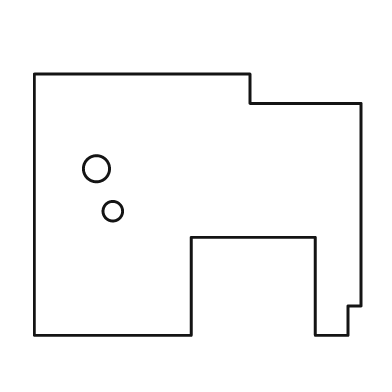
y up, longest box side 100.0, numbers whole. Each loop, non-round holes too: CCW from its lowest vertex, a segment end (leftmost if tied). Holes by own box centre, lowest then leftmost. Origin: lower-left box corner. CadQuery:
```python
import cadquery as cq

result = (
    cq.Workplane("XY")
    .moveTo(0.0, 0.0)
    .lineTo(48.0, 0.0)
    .lineTo(48.0, 30.0)
    .lineTo(86.0, 30.0)
    .lineTo(86.0, 0.0)
    .lineTo(96.0, 0.0)
    .lineTo(96.0, 9.0)
    .lineTo(100.0, 9.0)
    .lineTo(100.0, 71.0)
    .lineTo(66.0, 71.0)
    .lineTo(66.0, 80.0)
    .lineTo(0.0, 80.0)
    .close()
    .moveTo(24.0, 38.0)
    .circle(3.0)
    .moveTo(19.0, 51.0)
    .circle(4.0)
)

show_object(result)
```